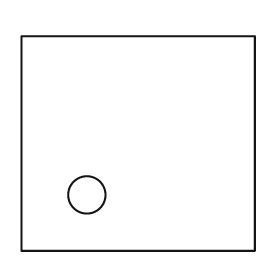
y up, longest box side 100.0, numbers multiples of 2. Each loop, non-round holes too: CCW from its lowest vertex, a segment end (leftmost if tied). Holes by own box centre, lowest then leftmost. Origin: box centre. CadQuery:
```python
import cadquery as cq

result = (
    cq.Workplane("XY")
    .moveTo(-50.0, -46.0)
    .lineTo(50.0, -46.0)
    .lineTo(50.0, 46.0)
    .lineTo(-50.0, 46.0)
    .close()
    .moveTo(-22.0, -22.0)
    .circle(8.0)
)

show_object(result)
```